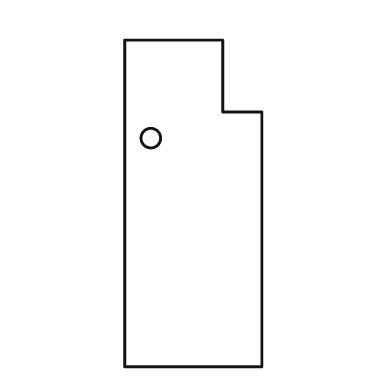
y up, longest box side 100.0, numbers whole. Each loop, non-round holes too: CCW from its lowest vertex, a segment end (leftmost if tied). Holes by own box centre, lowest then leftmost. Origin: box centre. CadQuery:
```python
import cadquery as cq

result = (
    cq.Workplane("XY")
    .moveTo(-21.0, -50.0)
    .lineTo(21.0, -50.0)
    .lineTo(21.0, 28.0)
    .lineTo(9.0, 28.0)
    .lineTo(9.0, 50.0)
    .lineTo(-21.0, 50.0)
    .close()
    .moveTo(-13.0, 20.0)
    .circle(3.0)
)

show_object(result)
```